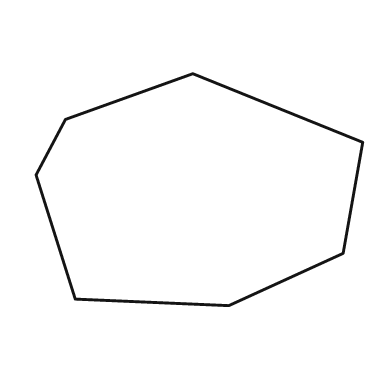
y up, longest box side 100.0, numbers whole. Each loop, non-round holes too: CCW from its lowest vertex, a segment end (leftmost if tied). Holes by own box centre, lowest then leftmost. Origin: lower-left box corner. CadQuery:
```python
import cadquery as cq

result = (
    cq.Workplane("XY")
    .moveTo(59.0, 0.0)
    .lineTo(94.0, 16.0)
    .lineTo(100.0, 50.0)
    .lineTo(48.0, 71.0)
    .lineTo(9.0, 57.0)
    .lineTo(0.0, 40.0)
    .lineTo(12.0, 2.0)
    .close()
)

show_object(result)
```